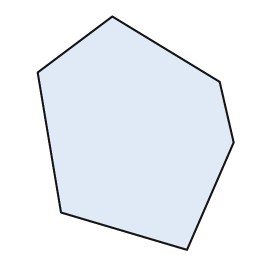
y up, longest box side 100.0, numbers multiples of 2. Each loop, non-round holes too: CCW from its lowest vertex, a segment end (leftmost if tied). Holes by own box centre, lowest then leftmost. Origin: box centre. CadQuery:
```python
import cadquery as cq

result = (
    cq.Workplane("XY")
    .moveTo(22.0, -50.0)
    .lineTo(42.0, -4.0)
    .lineTo(36.0, 22.0)
    .lineTo(-10.0, 50.0)
    .lineTo(-42.0, 26.0)
    .lineTo(-32.0, -34.0)
    .close()
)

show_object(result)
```